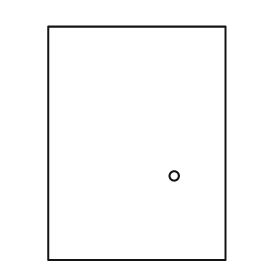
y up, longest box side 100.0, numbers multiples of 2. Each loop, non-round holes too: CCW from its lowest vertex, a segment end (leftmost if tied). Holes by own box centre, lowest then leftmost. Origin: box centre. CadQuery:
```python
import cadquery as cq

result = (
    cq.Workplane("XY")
    .moveTo(-38.0, -50.0)
    .lineTo(38.0, -50.0)
    .lineTo(38.0, 50.0)
    .lineTo(-38.0, 50.0)
    .close()
    .moveTo(16.0, -14.0)
    .circle(2.0)
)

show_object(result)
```